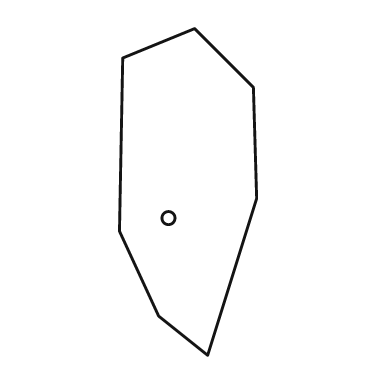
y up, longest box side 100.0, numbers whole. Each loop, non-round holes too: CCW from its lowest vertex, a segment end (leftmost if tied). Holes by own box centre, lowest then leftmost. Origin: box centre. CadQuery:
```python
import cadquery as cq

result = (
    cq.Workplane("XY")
    .moveTo(6.0, -50.0)
    .lineTo(21.0, -2.0)
    .lineTo(20.0, 32.0)
    .lineTo(2.0, 50.0)
    .lineTo(-20.0, 41.0)
    .lineTo(-21.0, -12.0)
    .lineTo(-9.0, -38.0)
    .close()
    .moveTo(-6.0, -8.0)
    .circle(2.0)
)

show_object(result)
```